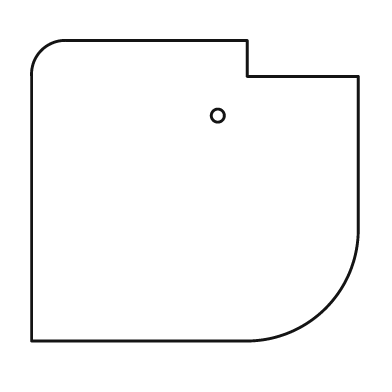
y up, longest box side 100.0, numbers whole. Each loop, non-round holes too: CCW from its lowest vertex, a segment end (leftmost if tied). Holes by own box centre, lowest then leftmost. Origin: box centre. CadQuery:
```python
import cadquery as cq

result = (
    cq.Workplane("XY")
    .moveTo(-50.0, -46.0)
    .lineTo(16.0, -46.0)
    .threePointArc((40.0, -36.0), (50.0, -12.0))
    .lineTo(50.0, 35.0)
    .lineTo(16.0, 35.0)
    .lineTo(16.0, 46.0)
    .lineTo(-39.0, 46.0)
    .threePointArc((-47.0, 43.0), (-50.0, 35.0))
    .close()
    .moveTo(7.0, 23.0)
    .circle(2.0)
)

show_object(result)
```